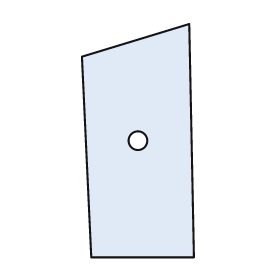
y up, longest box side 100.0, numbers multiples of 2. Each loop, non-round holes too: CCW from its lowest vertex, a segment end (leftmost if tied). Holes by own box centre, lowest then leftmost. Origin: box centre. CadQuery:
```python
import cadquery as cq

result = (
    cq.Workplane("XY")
    .moveTo(-20.0, -50.0)
    .lineTo(24.0, -50.0)
    .lineTo(22.0, 50.0)
    .lineTo(-24.0, 36.0)
    .close()
    .moveTo(0.0, 0.0)
    .circle(4.0)
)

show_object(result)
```